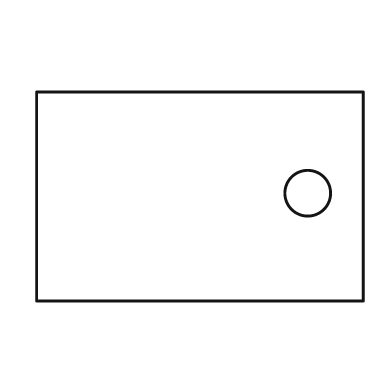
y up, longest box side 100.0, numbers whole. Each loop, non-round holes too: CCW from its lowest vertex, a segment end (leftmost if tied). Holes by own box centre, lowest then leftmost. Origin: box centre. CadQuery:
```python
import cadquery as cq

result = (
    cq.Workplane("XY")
    .moveTo(-50.0, -32.0)
    .lineTo(50.0, -32.0)
    .lineTo(50.0, 32.0)
    .lineTo(-50.0, 32.0)
    .close()
    .moveTo(33.0, 1.0)
    .circle(7.0)
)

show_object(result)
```